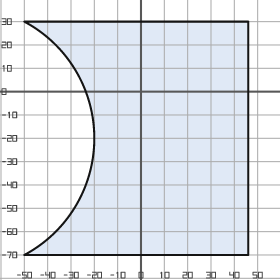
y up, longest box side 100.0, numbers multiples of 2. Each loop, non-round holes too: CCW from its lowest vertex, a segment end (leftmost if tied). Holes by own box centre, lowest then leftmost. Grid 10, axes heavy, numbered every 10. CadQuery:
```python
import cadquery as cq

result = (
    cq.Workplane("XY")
    .moveTo(-50.0, -70.0)
    .lineTo(46.0, -70.0)
    .lineTo(46.0, 30.0)
    .lineTo(-50.0, 30.0)
    .threePointArc((-20.0, -20.0), (-50.0, -70.0))
    .close()
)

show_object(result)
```